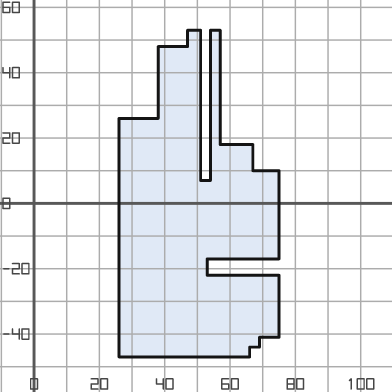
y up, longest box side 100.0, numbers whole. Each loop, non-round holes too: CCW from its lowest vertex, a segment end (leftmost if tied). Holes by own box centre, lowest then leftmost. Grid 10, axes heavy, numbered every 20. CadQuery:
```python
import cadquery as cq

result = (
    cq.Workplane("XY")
    .moveTo(26.0, -47.0)
    .lineTo(66.0, -47.0)
    .lineTo(66.0, -44.0)
    .lineTo(69.0, -44.0)
    .lineTo(69.0, -41.0)
    .lineTo(75.0, -41.0)
    .lineTo(75.0, -22.0)
    .lineTo(53.0, -22.0)
    .lineTo(53.0, -17.0)
    .lineTo(75.0, -17.0)
    .lineTo(75.0, 10.0)
    .lineTo(67.0, 10.0)
    .lineTo(67.0, 18.0)
    .lineTo(57.0, 18.0)
    .lineTo(57.0, 53.0)
    .lineTo(54.0, 53.0)
    .lineTo(54.0, 7.0)
    .lineTo(51.0, 7.0)
    .lineTo(51.0, 53.0)
    .lineTo(47.0, 53.0)
    .lineTo(47.0, 48.0)
    .lineTo(38.0, 48.0)
    .lineTo(38.0, 26.0)
    .lineTo(26.0, 26.0)
    .close()
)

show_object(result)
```